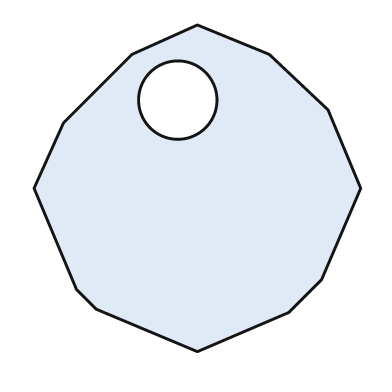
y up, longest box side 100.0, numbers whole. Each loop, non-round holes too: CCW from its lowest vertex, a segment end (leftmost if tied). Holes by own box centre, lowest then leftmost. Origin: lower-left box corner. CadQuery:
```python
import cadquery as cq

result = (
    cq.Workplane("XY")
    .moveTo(50.0, 0.0)
    .lineTo(78.0, 12.0)
    .lineTo(88.0, 22.0)
    .lineTo(100.0, 50.0)
    .lineTo(90.0, 74.0)
    .lineTo(72.0, 91.0)
    .lineTo(50.0, 100.0)
    .lineTo(30.0, 91.0)
    .lineTo(9.0, 70.0)
    .lineTo(0.0, 50.0)
    .lineTo(13.0, 19.0)
    .lineTo(19.0, 13.0)
    .close()
    .moveTo(44.0, 77.0)
    .circle(12.0)
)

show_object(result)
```